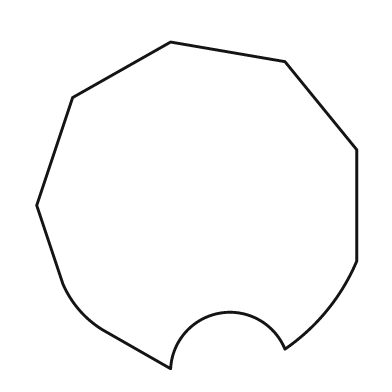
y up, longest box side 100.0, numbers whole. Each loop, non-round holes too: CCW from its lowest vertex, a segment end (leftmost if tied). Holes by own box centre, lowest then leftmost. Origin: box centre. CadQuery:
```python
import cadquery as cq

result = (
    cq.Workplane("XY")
    .moveTo(-8.0, -50.0)
    .threePointArc((7.0, -33.0), (27.0, -44.0))
    .threePointArc((40.0, -32.0), (49.0, -17.0))
    .lineTo(49.0, 17.0)
    .lineTo(27.0, 44.0)
    .lineTo(-8.0, 50.0)
    .lineTo(-38.0, 33.0)
    .lineTo(-49.0, 0.0)
    .lineTo(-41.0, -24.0)
    .threePointArc((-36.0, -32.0), (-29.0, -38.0))
    .close()
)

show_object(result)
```